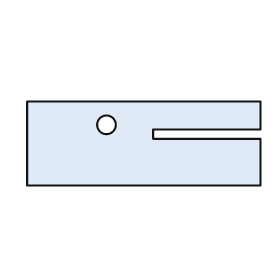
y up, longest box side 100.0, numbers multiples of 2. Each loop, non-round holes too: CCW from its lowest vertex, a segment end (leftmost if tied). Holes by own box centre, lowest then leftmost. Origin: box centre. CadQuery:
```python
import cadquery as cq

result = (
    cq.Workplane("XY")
    .moveTo(-50.0, -18.0)
    .lineTo(50.0, -18.0)
    .lineTo(50.0, 2.0)
    .lineTo(4.0, 2.0)
    .lineTo(4.0, 6.0)
    .lineTo(50.0, 6.0)
    .lineTo(50.0, 18.0)
    .lineTo(-50.0, 18.0)
    .close()
    .moveTo(-16.0, 8.0)
    .circle(4.0)
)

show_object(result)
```